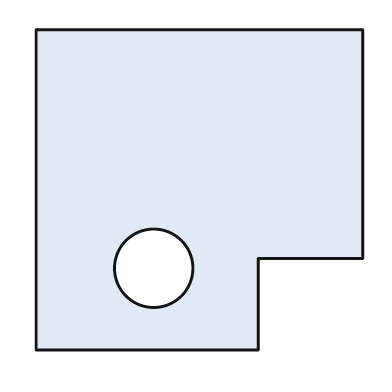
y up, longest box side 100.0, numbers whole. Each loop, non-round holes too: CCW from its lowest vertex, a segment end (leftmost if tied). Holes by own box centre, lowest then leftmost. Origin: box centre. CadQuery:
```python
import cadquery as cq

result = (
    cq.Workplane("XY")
    .moveTo(-50.0, -49.0)
    .lineTo(18.0, -49.0)
    .lineTo(18.0, -21.0)
    .lineTo(50.0, -21.0)
    .lineTo(50.0, 49.0)
    .lineTo(-50.0, 49.0)
    .close()
    .moveTo(-14.0, -24.0)
    .circle(12.0)
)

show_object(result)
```